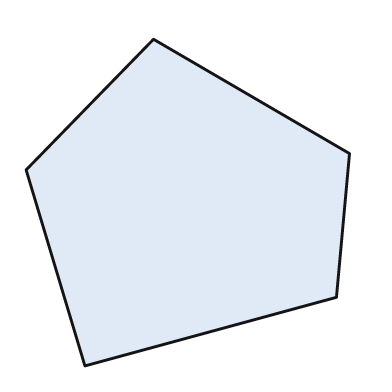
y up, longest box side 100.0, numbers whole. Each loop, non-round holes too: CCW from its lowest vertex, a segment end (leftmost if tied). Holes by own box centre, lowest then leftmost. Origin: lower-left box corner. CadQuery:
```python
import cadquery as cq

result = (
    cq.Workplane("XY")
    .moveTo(18.0, 0.0)
    .lineTo(95.0, 21.0)
    .lineTo(99.0, 65.0)
    .lineTo(39.0, 100.0)
    .lineTo(0.0, 60.0)
    .close()
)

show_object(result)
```